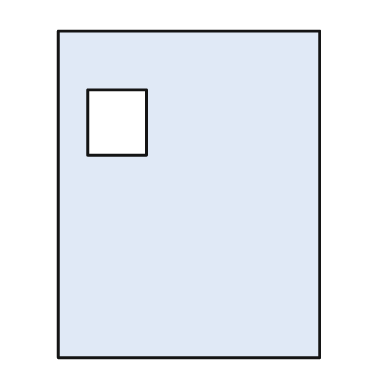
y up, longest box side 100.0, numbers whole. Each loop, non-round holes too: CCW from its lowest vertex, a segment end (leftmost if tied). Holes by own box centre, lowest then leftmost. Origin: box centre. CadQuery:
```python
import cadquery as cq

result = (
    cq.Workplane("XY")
    .moveTo(-40.0, -50.0)
    .lineTo(40.0, -50.0)
    .lineTo(40.0, 50.0)
    .lineTo(-40.0, 50.0)
    .close()
    .moveTo(-31.0, 12.0)
    .lineTo(-13.0, 12.0)
    .lineTo(-13.0, 32.0)
    .lineTo(-31.0, 32.0)
    .close()
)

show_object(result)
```